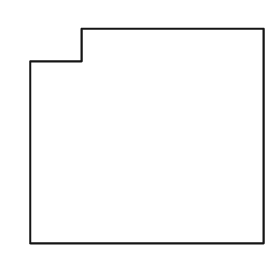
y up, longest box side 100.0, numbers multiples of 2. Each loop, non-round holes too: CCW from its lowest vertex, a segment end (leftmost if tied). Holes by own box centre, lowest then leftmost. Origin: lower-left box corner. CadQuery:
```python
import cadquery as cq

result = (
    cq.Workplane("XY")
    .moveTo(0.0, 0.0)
    .lineTo(100.0, 0.0)
    .lineTo(100.0, 92.0)
    .lineTo(22.0, 92.0)
    .lineTo(22.0, 78.0)
    .lineTo(0.0, 78.0)
    .close()
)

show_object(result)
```